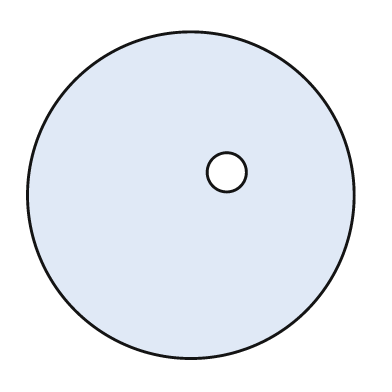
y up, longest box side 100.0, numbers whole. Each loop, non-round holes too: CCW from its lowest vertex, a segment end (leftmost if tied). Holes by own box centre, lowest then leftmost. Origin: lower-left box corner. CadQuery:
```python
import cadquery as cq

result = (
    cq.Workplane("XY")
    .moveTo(50.0, 50.0)
    .circle(50.0)
    .moveTo(61.0, 57.0)
    .circle(6.0)
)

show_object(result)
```